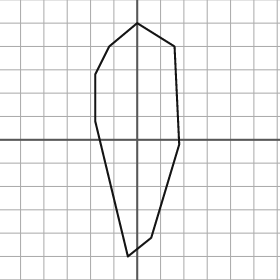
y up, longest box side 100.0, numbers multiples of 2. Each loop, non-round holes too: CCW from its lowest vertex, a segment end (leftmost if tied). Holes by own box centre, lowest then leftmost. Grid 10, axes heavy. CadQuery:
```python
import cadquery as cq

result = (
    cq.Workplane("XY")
    .moveTo(-4.0, -50.0)
    .lineTo(6.0, -42.0)
    .lineTo(18.0, -2.0)
    .lineTo(16.0, 40.0)
    .lineTo(0.0, 50.0)
    .lineTo(-12.0, 40.0)
    .lineTo(-18.0, 28.0)
    .lineTo(-18.0, 8.0)
    .close()
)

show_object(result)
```